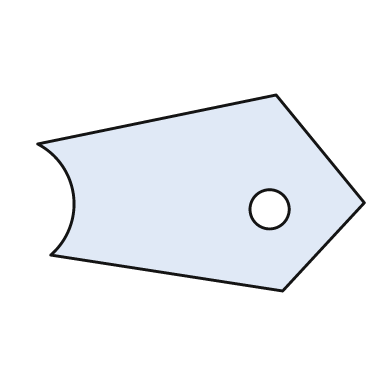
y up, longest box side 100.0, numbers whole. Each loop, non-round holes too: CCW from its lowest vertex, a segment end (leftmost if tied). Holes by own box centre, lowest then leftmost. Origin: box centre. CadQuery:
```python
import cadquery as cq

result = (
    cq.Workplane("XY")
    .moveTo(25.0, -30.0)
    .lineTo(50.0, -3.0)
    .lineTo(23.0, 30.0)
    .lineTo(-50.0, 15.0)
    .threePointArc((-39.0, -1.0), (-46.0, -19.0))
    .close()
    .moveTo(21.0, -5.0)
    .circle(6.0)
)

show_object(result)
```